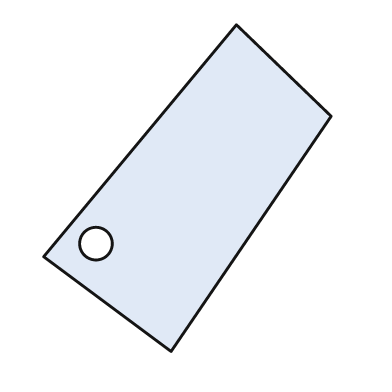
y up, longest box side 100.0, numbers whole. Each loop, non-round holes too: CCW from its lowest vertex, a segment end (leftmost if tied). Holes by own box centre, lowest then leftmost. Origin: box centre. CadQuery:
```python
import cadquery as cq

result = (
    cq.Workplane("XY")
    .moveTo(-5.0, -50.0)
    .lineTo(44.0, 22.0)
    .lineTo(15.0, 50.0)
    .lineTo(-44.0, -21.0)
    .close()
    .moveTo(-28.0, -17.0)
    .circle(5.0)
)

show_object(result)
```